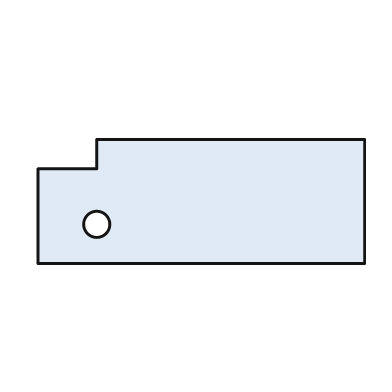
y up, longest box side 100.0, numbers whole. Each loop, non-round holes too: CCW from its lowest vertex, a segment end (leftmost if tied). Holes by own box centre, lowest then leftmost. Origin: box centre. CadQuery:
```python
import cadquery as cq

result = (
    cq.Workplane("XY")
    .moveTo(-50.0, -19.0)
    .lineTo(50.0, -19.0)
    .lineTo(50.0, 19.0)
    .lineTo(-32.0, 19.0)
    .lineTo(-32.0, 10.0)
    .lineTo(-50.0, 10.0)
    .close()
    .moveTo(-32.0, -7.0)
    .circle(4.0)
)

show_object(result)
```